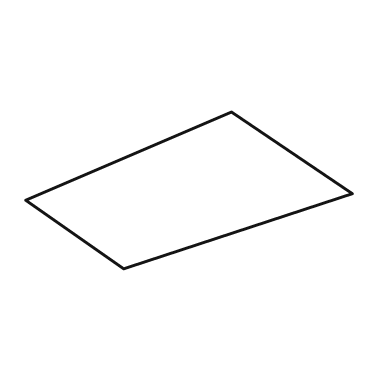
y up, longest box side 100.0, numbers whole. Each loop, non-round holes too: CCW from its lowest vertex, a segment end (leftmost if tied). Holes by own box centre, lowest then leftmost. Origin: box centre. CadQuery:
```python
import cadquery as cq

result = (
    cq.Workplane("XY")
    .moveTo(-20.0, -24.0)
    .lineTo(50.0, -1.0)
    .lineTo(13.0, 24.0)
    .lineTo(-50.0, -3.0)
    .close()
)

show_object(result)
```